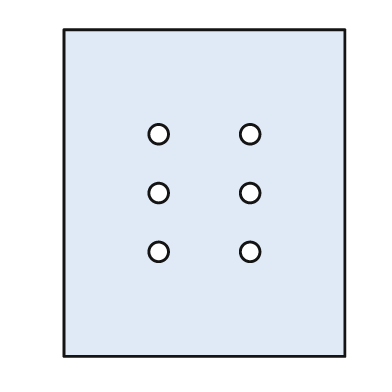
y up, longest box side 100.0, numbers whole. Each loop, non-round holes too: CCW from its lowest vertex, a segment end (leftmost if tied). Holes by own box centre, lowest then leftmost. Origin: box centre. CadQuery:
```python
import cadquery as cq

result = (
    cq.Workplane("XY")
    .moveTo(-43.0, -50.0)
    .lineTo(43.0, -50.0)
    .lineTo(43.0, 50.0)
    .lineTo(-43.0, 50.0)
    .close()
    .moveTo(-14.0, -18.0)
    .circle(3.0)
    .moveTo(14.0, -18.0)
    .circle(3.0)
    .moveTo(-14.0, 0.0)
    .circle(3.0)
    .moveTo(14.0, 0.0)
    .circle(3.0)
    .moveTo(-14.0, 18.0)
    .circle(3.0)
    .moveTo(14.0, 18.0)
    .circle(3.0)
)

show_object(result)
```